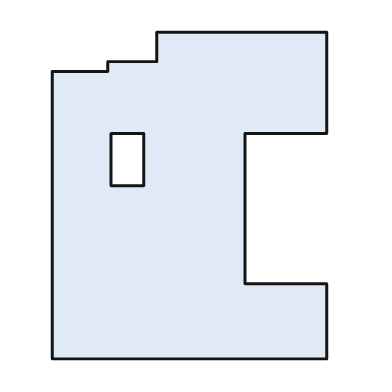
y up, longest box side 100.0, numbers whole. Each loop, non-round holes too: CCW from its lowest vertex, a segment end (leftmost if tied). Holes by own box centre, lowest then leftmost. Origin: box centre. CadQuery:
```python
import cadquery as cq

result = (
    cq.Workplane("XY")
    .moveTo(-42.0, -50.0)
    .lineTo(42.0, -50.0)
    .lineTo(42.0, -27.0)
    .lineTo(17.0, -27.0)
    .lineTo(17.0, 19.0)
    .lineTo(42.0, 19.0)
    .lineTo(42.0, 50.0)
    .lineTo(-10.0, 50.0)
    .lineTo(-10.0, 41.0)
    .lineTo(-25.0, 41.0)
    .lineTo(-25.0, 38.0)
    .lineTo(-42.0, 38.0)
    .close()
    .moveTo(-24.0, 3.0)
    .lineTo(-14.0, 3.0)
    .lineTo(-14.0, 19.0)
    .lineTo(-24.0, 19.0)
    .close()
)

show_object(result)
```